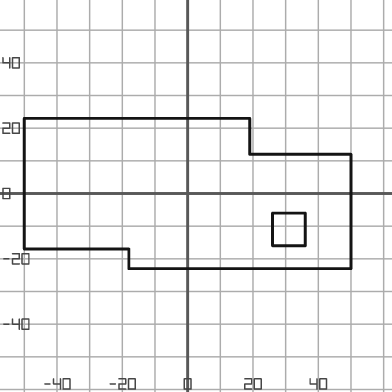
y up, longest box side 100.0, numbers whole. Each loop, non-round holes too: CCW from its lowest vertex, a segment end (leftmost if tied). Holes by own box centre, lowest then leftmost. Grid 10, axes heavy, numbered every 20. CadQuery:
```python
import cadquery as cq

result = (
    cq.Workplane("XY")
    .moveTo(-18.0, -23.0)
    .lineTo(50.0, -23.0)
    .lineTo(50.0, 12.0)
    .lineTo(19.0, 12.0)
    .lineTo(19.0, 23.0)
    .lineTo(-50.0, 23.0)
    .lineTo(-50.0, -17.0)
    .lineTo(-18.0, -17.0)
    .close()
    .moveTo(26.0, -16.0)
    .lineTo(36.0, -16.0)
    .lineTo(36.0, -6.0)
    .lineTo(26.0, -6.0)
    .close()
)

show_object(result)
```